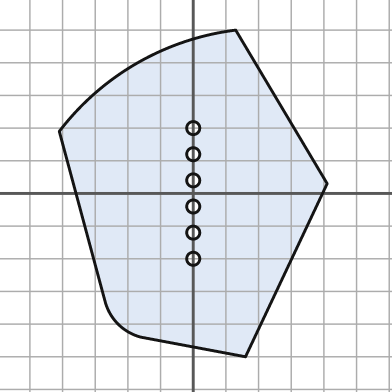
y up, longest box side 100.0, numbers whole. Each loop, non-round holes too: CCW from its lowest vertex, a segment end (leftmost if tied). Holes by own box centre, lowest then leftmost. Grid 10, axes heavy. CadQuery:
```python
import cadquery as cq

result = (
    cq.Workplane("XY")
    .moveTo(16.0, -50.0)
    .lineTo(41.0, 3.0)
    .lineTo(13.0, 50.0)
    .threePointArc((-17.0, 40.0), (-41.0, 19.0))
    .lineTo(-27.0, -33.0)
    .threePointArc((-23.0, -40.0), (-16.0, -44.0))
    .close()
    .moveTo(0.0, -20.0)
    .circle(2.0)
    .moveTo(0.0, -12.0)
    .circle(2.0)
    .moveTo(0.0, -4.0)
    .circle(2.0)
    .moveTo(0.0, 4.0)
    .circle(2.0)
    .moveTo(0.0, 12.0)
    .circle(2.0)
    .moveTo(0.0, 20.0)
    .circle(2.0)
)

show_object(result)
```